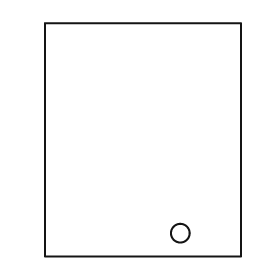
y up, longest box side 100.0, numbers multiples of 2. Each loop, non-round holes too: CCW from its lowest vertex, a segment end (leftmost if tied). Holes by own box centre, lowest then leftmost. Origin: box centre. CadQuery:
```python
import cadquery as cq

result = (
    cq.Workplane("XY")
    .moveTo(-42.0, -50.0)
    .lineTo(42.0, -50.0)
    .lineTo(42.0, 50.0)
    .lineTo(-42.0, 50.0)
    .close()
    .moveTo(16.0, -40.0)
    .circle(4.0)
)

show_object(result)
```